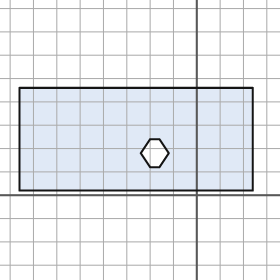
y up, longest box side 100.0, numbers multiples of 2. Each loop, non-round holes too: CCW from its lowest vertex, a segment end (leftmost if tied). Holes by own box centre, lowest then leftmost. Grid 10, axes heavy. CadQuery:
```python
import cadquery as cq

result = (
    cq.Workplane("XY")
    .moveTo(-76.0, 2.0)
    .lineTo(24.0, 2.0)
    .lineTo(24.0, 46.0)
    .lineTo(-76.0, 46.0)
    .close()
    .moveTo(-20.0, 12.0)
    .lineTo(-16.0, 12.0)
    .lineTo(-12.0, 18.0)
    .lineTo(-16.0, 24.0)
    .lineTo(-20.0, 24.0)
    .lineTo(-24.0, 18.0)
    .close()
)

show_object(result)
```